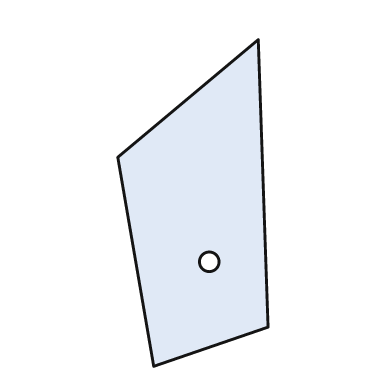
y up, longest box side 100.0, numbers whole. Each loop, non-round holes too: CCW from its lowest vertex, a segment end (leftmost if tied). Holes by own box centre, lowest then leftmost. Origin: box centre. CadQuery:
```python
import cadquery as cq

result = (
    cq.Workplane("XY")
    .moveTo(-12.0, -50.0)
    .lineTo(23.0, -38.0)
    .lineTo(20.0, 50.0)
    .lineTo(-23.0, 14.0)
    .close()
    .moveTo(5.0, -18.0)
    .circle(3.0)
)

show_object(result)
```